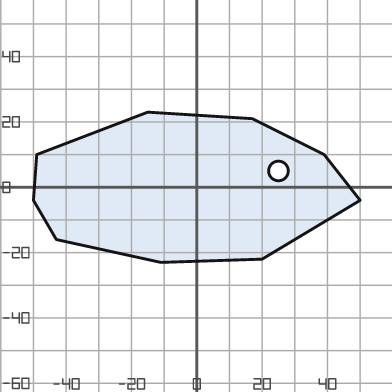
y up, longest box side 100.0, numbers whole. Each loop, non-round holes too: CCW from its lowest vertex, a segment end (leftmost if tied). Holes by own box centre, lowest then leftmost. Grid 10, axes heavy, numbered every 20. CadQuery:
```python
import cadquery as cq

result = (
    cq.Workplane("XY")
    .moveTo(-11.0, -23.0)
    .lineTo(20.0, -22.0)
    .lineTo(50.0, -4.0)
    .lineTo(39.0, 10.0)
    .lineTo(17.0, 21.0)
    .lineTo(-15.0, 23.0)
    .lineTo(-49.0, 10.0)
    .lineTo(-50.0, -4.0)
    .lineTo(-43.0, -16.0)
    .close()
    .moveTo(25.0, 5.0)
    .circle(3.0)
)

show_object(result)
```